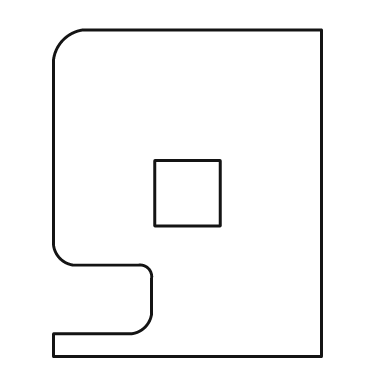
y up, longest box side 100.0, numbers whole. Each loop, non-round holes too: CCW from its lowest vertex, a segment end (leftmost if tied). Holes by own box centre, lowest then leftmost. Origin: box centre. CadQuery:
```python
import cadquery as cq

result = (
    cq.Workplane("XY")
    .moveTo(-41.0, -50.0)
    .lineTo(41.0, -50.0)
    .lineTo(41.0, 50.0)
    .lineTo(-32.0, 50.0)
    .threePointArc((-38.0, 47.0), (-41.0, 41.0))
    .lineTo(-41.0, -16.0)
    .threePointArc((-39.0, -20.0), (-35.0, -22.0))
    .lineTo(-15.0, -22.0)
    .threePointArc((-12.0, -23.0), (-11.0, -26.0))
    .lineTo(-11.0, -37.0)
    .threePointArc((-13.0, -41.0), (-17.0, -43.0))
    .lineTo(-41.0, -43.0)
    .close()
    .moveTo(-10.0, -10.0)
    .lineTo(10.0, -10.0)
    .lineTo(10.0, 10.0)
    .lineTo(-10.0, 10.0)
    .close()
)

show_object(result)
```